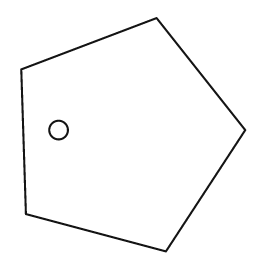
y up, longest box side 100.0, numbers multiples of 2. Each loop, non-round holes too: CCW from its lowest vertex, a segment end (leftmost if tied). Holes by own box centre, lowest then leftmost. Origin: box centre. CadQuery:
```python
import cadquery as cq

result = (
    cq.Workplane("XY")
    .moveTo(14.0, -50.0)
    .lineTo(48.0, 2.0)
    .lineTo(10.0, 50.0)
    .lineTo(-48.0, 28.0)
    .lineTo(-46.0, -34.0)
    .close()
    .moveTo(-32.0, 2.0)
    .circle(4.0)
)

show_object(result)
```